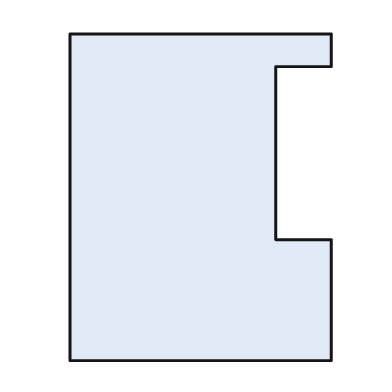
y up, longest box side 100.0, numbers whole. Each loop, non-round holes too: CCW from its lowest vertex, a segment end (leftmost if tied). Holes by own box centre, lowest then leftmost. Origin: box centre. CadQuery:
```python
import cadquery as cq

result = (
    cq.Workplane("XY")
    .moveTo(-40.0, -50.0)
    .lineTo(40.0, -50.0)
    .lineTo(40.0, -13.0)
    .lineTo(23.0, -13.0)
    .lineTo(23.0, 40.0)
    .lineTo(40.0, 40.0)
    .lineTo(40.0, 50.0)
    .lineTo(-40.0, 50.0)
    .close()
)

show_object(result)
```